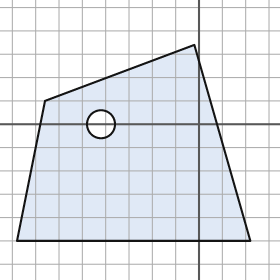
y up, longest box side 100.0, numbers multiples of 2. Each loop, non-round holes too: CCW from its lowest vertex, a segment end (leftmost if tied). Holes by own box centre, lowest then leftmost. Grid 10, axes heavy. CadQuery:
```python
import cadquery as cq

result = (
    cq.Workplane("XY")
    .moveTo(-78.0, -50.0)
    .lineTo(22.0, -50.0)
    .lineTo(-2.0, 34.0)
    .lineTo(-66.0, 10.0)
    .close()
    .moveTo(-42.0, 0.0)
    .circle(6.0)
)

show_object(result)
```